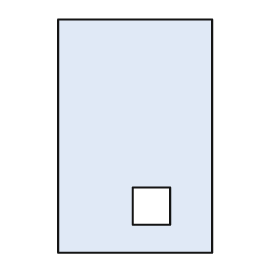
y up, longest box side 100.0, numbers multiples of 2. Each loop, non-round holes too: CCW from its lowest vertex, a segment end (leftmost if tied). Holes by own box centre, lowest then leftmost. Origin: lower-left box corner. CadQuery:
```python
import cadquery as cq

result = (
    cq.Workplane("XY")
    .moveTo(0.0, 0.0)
    .lineTo(66.0, 0.0)
    .lineTo(66.0, 100.0)
    .lineTo(0.0, 100.0)
    .close()
    .moveTo(32.0, 12.0)
    .lineTo(48.0, 12.0)
    .lineTo(48.0, 28.0)
    .lineTo(32.0, 28.0)
    .close()
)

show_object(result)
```